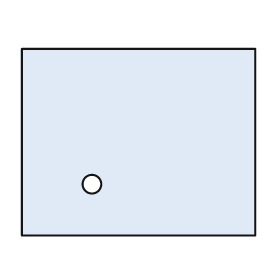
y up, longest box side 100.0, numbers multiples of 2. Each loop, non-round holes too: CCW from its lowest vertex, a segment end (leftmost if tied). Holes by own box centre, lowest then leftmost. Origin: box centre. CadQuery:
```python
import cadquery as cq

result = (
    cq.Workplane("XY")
    .moveTo(-50.0, -40.0)
    .lineTo(50.0, -40.0)
    .lineTo(50.0, 40.0)
    .lineTo(-50.0, 40.0)
    .close()
    .moveTo(-20.0, -18.0)
    .circle(4.0)
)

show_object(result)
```